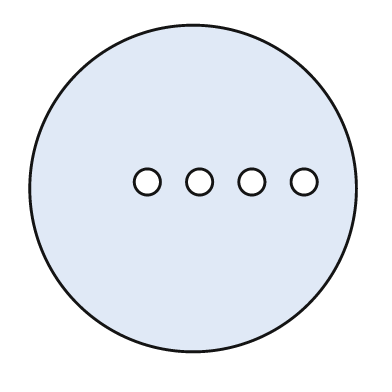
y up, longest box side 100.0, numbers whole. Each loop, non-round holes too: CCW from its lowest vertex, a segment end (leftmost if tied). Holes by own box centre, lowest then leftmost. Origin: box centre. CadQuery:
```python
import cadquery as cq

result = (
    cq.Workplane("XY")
    .moveTo(0.0, 0.0)
    .circle(50.0)
    .moveTo(-14.0, 2.0)
    .circle(4.0)
    .moveTo(2.0, 2.0)
    .circle(4.0)
    .moveTo(18.0, 2.0)
    .circle(4.0)
    .moveTo(34.0, 2.0)
    .circle(4.0)
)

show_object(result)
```